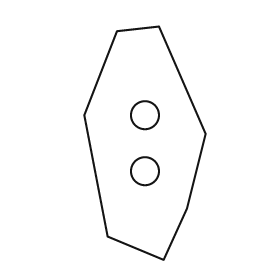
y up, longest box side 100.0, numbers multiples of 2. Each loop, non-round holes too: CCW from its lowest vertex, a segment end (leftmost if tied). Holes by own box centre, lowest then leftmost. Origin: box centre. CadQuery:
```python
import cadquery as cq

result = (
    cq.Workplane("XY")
    .moveTo(8.0, -50.0)
    .lineTo(18.0, -28.0)
    .lineTo(26.0, 4.0)
    .lineTo(6.0, 50.0)
    .lineTo(-12.0, 48.0)
    .lineTo(-26.0, 12.0)
    .lineTo(-16.0, -40.0)
    .close()
    .moveTo(0.0, -12.0)
    .circle(6.0)
    .moveTo(0.0, 12.0)
    .circle(6.0)
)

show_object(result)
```